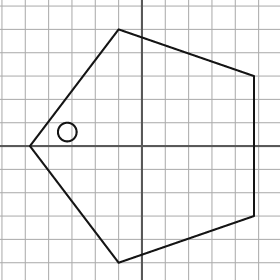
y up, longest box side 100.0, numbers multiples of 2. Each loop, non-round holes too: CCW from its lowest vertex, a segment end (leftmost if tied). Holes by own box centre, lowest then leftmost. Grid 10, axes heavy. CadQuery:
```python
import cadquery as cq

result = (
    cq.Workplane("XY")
    .moveTo(-10.0, -50.0)
    .lineTo(48.0, -30.0)
    .lineTo(48.0, 30.0)
    .lineTo(-10.0, 50.0)
    .lineTo(-48.0, 0.0)
    .close()
    .moveTo(-32.0, 6.0)
    .circle(4.0)
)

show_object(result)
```